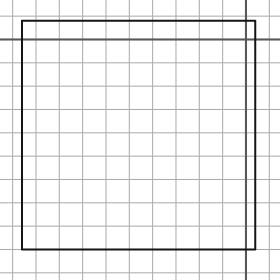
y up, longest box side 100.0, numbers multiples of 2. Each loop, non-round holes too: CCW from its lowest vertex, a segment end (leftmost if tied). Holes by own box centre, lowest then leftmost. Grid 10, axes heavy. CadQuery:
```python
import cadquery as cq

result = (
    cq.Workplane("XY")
    .moveTo(-96.0, -90.0)
    .lineTo(4.0, -90.0)
    .lineTo(4.0, 8.0)
    .lineTo(-96.0, 8.0)
    .close()
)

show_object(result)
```